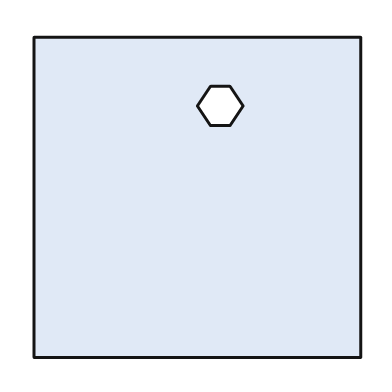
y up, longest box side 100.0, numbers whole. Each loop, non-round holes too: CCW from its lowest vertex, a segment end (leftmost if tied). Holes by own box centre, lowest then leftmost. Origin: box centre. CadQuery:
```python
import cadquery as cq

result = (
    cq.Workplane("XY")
    .moveTo(-50.0, -49.0)
    .lineTo(50.0, -49.0)
    .lineTo(50.0, 49.0)
    .lineTo(-50.0, 49.0)
    .close()
    .moveTo(4.0, 22.0)
    .lineTo(10.0, 22.0)
    .lineTo(14.0, 28.0)
    .lineTo(10.0, 34.0)
    .lineTo(4.0, 34.0)
    .lineTo(0.0, 28.0)
    .close()
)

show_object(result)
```